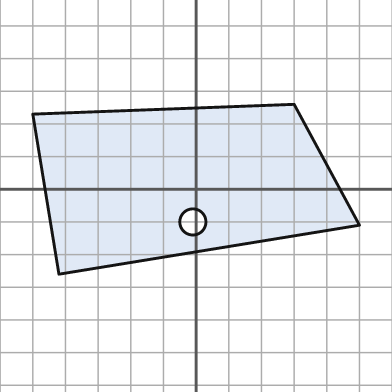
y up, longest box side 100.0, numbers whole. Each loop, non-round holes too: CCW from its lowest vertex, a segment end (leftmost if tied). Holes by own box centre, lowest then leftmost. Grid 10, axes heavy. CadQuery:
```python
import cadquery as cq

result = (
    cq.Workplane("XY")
    .moveTo(-42.0, -26.0)
    .lineTo(50.0, -11.0)
    .lineTo(30.0, 26.0)
    .lineTo(-50.0, 23.0)
    .close()
    .moveTo(-1.0, -10.0)
    .circle(4.0)
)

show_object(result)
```